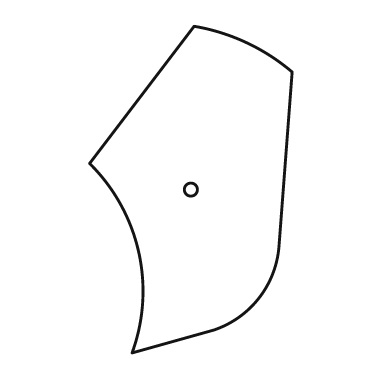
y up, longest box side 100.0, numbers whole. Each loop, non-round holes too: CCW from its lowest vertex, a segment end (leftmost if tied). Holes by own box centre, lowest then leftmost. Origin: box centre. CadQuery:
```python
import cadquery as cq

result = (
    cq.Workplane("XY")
    .moveTo(-18.0, -50.0)
    .lineTo(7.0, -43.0)
    .threePointArc((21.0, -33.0), (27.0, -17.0))
    .lineTo(31.0, 36.0)
    .threePointArc((17.0, 45.0), (1.0, 50.0))
    .lineTo(-31.0, 8.0)
    .threePointArc((-16.0, -19.0), (-18.0, -50.0))
    .close()
    .moveTo(0.0, 0.0)
    .circle(2.0)
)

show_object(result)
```